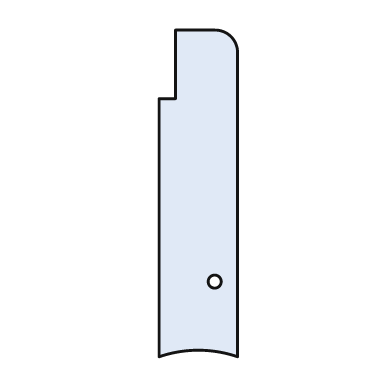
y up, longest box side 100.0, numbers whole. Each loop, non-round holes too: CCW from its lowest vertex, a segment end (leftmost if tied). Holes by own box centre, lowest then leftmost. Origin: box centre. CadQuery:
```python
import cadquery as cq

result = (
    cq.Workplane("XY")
    .moveTo(-12.0, -50.0)
    .threePointArc((0.0, -48.0), (12.0, -50.0))
    .lineTo(12.0, 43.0)
    .threePointArc((10.0, 48.0), (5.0, 50.0))
    .lineTo(-7.0, 50.0)
    .lineTo(-7.0, 29.0)
    .lineTo(-12.0, 29.0)
    .close()
    .moveTo(5.0, -27.0)
    .circle(2.0)
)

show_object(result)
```